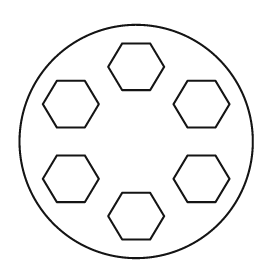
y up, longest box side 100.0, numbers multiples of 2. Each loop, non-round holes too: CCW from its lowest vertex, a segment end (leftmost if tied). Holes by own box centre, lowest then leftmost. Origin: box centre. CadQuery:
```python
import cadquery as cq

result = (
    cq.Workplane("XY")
    .moveTo(0.0, 0.0)
    .circle(50.0)
    .moveTo(-6.0, -42.0)
    .lineTo(6.0, -42.0)
    .lineTo(12.0, -32.0)
    .lineTo(6.0, -22.0)
    .lineTo(-6.0, -22.0)
    .lineTo(-12.0, -32.0)
    .close()
    .moveTo(-34.0, -26.0)
    .lineTo(-22.0, -26.0)
    .lineTo(-16.0, -16.0)
    .lineTo(-22.0, -6.0)
    .lineTo(-34.0, -6.0)
    .lineTo(-40.0, -16.0)
    .close()
    .moveTo(22.0, -26.0)
    .lineTo(34.0, -26.0)
    .lineTo(40.0, -16.0)
    .lineTo(34.0, -6.0)
    .lineTo(22.0, -6.0)
    .lineTo(16.0, -16.0)
    .close()
    .moveTo(-34.0, 6.0)
    .lineTo(-22.0, 6.0)
    .lineTo(-16.0, 16.0)
    .lineTo(-22.0, 26.0)
    .lineTo(-34.0, 26.0)
    .lineTo(-40.0, 16.0)
    .close()
    .moveTo(22.0, 6.0)
    .lineTo(34.0, 6.0)
    .lineTo(40.0, 16.0)
    .lineTo(34.0, 26.0)
    .lineTo(22.0, 26.0)
    .lineTo(16.0, 16.0)
    .close()
    .moveTo(-6.0, 22.0)
    .lineTo(6.0, 22.0)
    .lineTo(12.0, 32.0)
    .lineTo(6.0, 42.0)
    .lineTo(-6.0, 42.0)
    .lineTo(-12.0, 32.0)
    .close()
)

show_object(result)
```